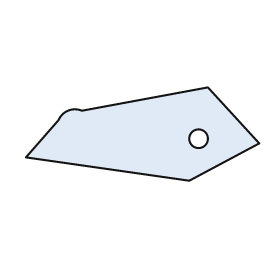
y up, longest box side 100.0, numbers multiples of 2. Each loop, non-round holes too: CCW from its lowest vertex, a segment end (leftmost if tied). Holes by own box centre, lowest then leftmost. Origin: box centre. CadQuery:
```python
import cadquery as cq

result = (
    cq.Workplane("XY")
    .moveTo(20.0, -20.0)
    .lineTo(50.0, -4.0)
    .lineTo(28.0, 20.0)
    .lineTo(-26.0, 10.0)
    .threePointArc((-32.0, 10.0), (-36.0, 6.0))
    .lineTo(-50.0, -10.0)
    .close()
    .moveTo(24.0, -2.0)
    .circle(4.0)
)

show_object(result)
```